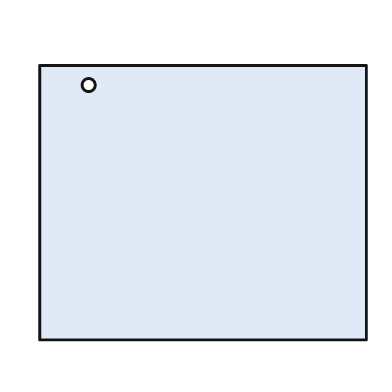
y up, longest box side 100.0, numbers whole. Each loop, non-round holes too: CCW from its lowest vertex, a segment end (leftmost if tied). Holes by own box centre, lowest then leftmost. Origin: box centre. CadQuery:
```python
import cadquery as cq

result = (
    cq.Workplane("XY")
    .moveTo(-50.0, -42.0)
    .lineTo(50.0, -42.0)
    .lineTo(50.0, 42.0)
    .lineTo(-50.0, 42.0)
    .close()
    .moveTo(-35.0, 36.0)
    .circle(2.0)
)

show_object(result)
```